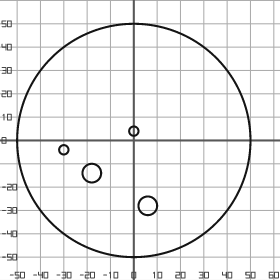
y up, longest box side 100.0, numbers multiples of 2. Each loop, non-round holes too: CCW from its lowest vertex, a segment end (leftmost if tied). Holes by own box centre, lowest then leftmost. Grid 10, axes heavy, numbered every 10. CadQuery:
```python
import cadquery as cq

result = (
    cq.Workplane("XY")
    .moveTo(0.0, 0.0)
    .circle(50.0)
    .moveTo(6.0, -28.0)
    .circle(4.0)
    .moveTo(-18.0, -14.0)
    .circle(4.0)
    .moveTo(-30.0, -4.0)
    .circle(2.0)
    .moveTo(0.0, 4.0)
    .circle(2.0)
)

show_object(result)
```